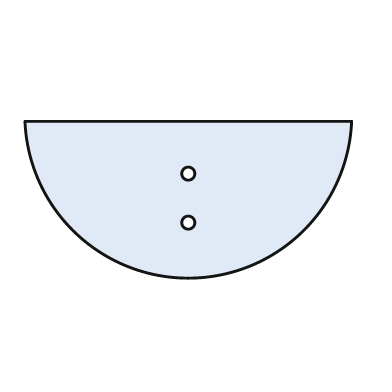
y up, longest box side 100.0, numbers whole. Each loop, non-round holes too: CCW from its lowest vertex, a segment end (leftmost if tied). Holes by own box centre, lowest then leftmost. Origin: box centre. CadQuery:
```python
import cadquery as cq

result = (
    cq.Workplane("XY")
    .moveTo(-50.0, 24.0)
    .threePointArc((0.0, -24.0), (50.0, 24.0))
    .close()
    .moveTo(0.0, -7.0)
    .circle(2.0)
    .moveTo(0.0, 8.0)
    .circle(2.0)
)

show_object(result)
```